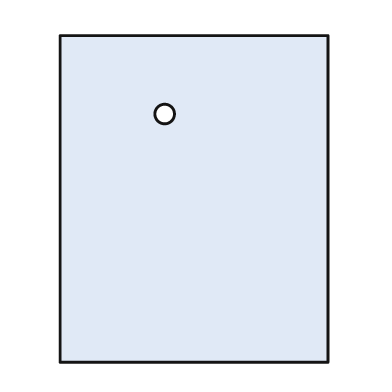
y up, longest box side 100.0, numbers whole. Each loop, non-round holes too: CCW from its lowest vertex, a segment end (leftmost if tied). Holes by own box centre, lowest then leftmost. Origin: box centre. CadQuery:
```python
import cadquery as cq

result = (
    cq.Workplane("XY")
    .moveTo(-41.0, -50.0)
    .lineTo(41.0, -50.0)
    .lineTo(41.0, 50.0)
    .lineTo(-41.0, 50.0)
    .close()
    .moveTo(-9.0, 26.0)
    .circle(3.0)
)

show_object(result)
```